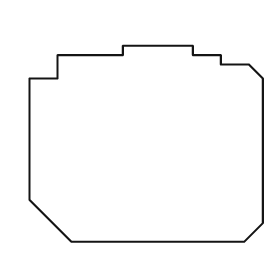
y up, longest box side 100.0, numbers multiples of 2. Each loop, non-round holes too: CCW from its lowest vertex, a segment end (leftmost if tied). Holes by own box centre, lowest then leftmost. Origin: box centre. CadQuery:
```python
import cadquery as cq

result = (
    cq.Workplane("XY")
    .moveTo(-32.0, -42.0)
    .lineTo(42.0, -42.0)
    .lineTo(50.0, -34.0)
    .lineTo(50.0, 28.0)
    .lineTo(44.0, 34.0)
    .lineTo(32.0, 34.0)
    .lineTo(32.0, 38.0)
    .lineTo(20.0, 38.0)
    .lineTo(20.0, 42.0)
    .lineTo(-10.0, 42.0)
    .lineTo(-10.0, 38.0)
    .lineTo(-38.0, 38.0)
    .lineTo(-38.0, 28.0)
    .lineTo(-50.0, 28.0)
    .lineTo(-50.0, -24.0)
    .close()
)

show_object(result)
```